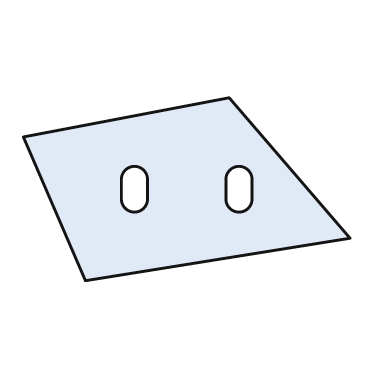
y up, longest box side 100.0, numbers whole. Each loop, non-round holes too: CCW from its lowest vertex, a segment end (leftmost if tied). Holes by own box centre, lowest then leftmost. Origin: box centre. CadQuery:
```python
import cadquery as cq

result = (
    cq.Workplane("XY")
    .moveTo(-31.0, -28.0)
    .lineTo(50.0, -15.0)
    .lineTo(13.0, 28.0)
    .lineTo(-50.0, 16.0)
    .close()
    .moveTo(-20.0, -3.0)
    .threePointArc((-16.0, -7.0), (-12.0, -3.0))
    .lineTo(-12.0, 3.0)
    .threePointArc((-16.0, 7.0), (-20.0, 3.0))
    .close()
    .moveTo(12.0, -3.0)
    .threePointArc((16.0, -7.0), (20.0, -3.0))
    .lineTo(20.0, 3.0)
    .threePointArc((16.0, 7.0), (12.0, 3.0))
    .close()
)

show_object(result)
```